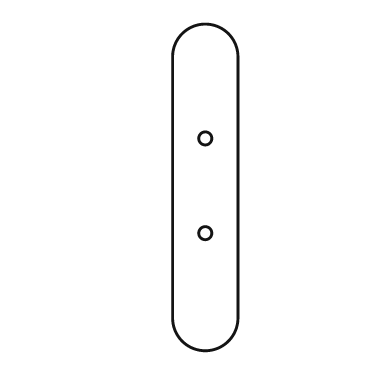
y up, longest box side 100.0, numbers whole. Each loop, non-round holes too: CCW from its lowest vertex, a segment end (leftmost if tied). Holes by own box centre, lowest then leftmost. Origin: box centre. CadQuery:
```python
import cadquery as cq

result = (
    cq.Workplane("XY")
    .moveTo(-10.0, -40.0)
    .threePointArc((0.0, -50.0), (10.0, -40.0))
    .lineTo(10.0, 40.0)
    .threePointArc((0.0, 50.0), (-10.0, 40.0))
    .close()
    .moveTo(0.0, -14.0)
    .circle(2.0)
    .moveTo(0.0, 15.0)
    .circle(2.0)
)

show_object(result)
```